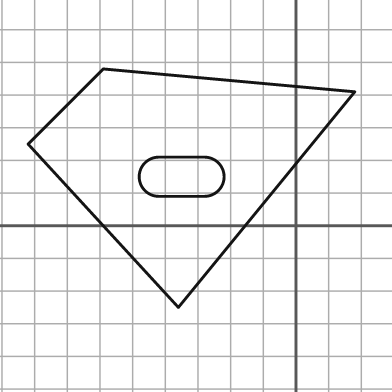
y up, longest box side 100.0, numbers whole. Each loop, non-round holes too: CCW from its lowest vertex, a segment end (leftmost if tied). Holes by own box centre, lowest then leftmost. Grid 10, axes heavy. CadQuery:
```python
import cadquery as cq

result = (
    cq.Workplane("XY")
    .moveTo(-36.0, -25.0)
    .lineTo(18.0, 41.0)
    .lineTo(-59.0, 48.0)
    .lineTo(-82.0, 25.0)
    .close()
    .moveTo(-42.0, 9.0)
    .lineTo(-28.0, 9.0)
    .threePointArc((-22.0, 15.0), (-28.0, 21.0))
    .lineTo(-42.0, 21.0)
    .threePointArc((-48.0, 15.0), (-42.0, 9.0))
    .close()
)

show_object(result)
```